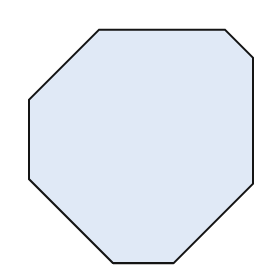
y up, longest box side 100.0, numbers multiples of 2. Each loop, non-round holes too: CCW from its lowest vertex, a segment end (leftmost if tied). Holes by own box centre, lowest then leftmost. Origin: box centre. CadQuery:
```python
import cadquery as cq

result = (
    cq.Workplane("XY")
    .moveTo(-12.0, -50.0)
    .lineTo(14.0, -50.0)
    .lineTo(48.0, -16.0)
    .lineTo(48.0, 38.0)
    .lineTo(36.0, 50.0)
    .lineTo(-18.0, 50.0)
    .lineTo(-48.0, 20.0)
    .lineTo(-48.0, -14.0)
    .close()
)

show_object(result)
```